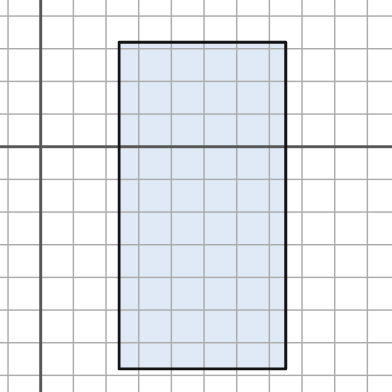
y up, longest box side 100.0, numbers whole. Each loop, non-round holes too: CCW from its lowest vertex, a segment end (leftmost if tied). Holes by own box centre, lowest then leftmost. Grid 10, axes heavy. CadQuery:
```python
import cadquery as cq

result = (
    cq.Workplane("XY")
    .moveTo(24.0, -68.0)
    .lineTo(75.0, -68.0)
    .lineTo(75.0, 32.0)
    .lineTo(24.0, 32.0)
    .close()
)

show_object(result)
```